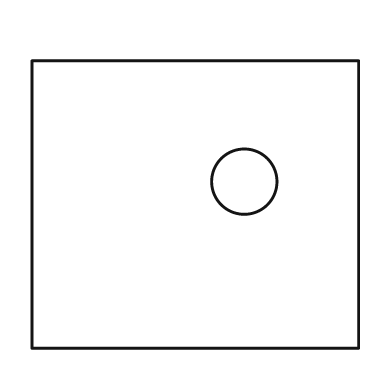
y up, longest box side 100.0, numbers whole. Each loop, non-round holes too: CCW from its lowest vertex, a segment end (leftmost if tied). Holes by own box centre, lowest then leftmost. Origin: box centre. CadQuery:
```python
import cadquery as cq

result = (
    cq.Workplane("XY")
    .moveTo(-50.0, -44.0)
    .lineTo(50.0, -44.0)
    .lineTo(50.0, 44.0)
    .lineTo(-50.0, 44.0)
    .close()
    .moveTo(15.0, 7.0)
    .circle(10.0)
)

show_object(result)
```